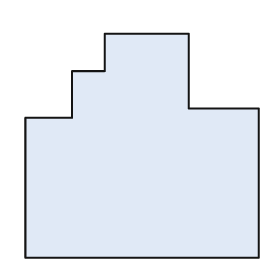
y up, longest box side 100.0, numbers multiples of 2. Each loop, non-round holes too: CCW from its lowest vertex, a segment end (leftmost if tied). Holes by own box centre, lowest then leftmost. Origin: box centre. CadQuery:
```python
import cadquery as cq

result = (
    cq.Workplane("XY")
    .moveTo(-50.0, -48.0)
    .lineTo(50.0, -48.0)
    .lineTo(50.0, 16.0)
    .lineTo(20.0, 16.0)
    .lineTo(20.0, 48.0)
    .lineTo(-16.0, 48.0)
    .lineTo(-16.0, 32.0)
    .lineTo(-30.0, 32.0)
    .lineTo(-30.0, 12.0)
    .lineTo(-50.0, 12.0)
    .close()
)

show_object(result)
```